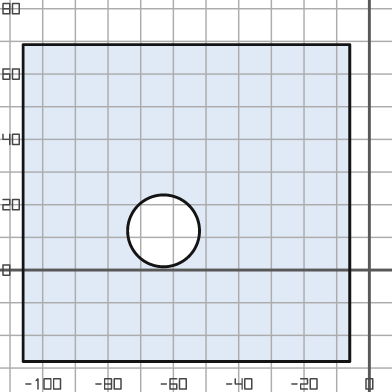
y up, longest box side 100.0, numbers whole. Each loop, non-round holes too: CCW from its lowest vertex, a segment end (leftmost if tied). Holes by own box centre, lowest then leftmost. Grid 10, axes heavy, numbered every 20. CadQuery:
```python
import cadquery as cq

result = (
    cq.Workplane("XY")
    .moveTo(-106.0, -28.0)
    .lineTo(-6.0, -28.0)
    .lineTo(-6.0, 69.0)
    .lineTo(-106.0, 69.0)
    .close()
    .moveTo(-63.0, 12.0)
    .circle(11.0)
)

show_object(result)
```